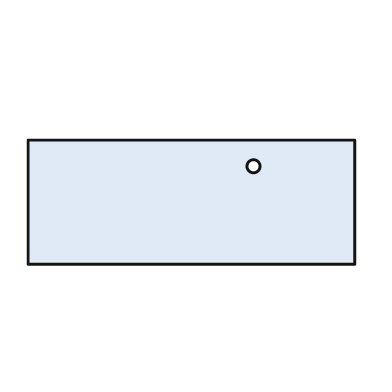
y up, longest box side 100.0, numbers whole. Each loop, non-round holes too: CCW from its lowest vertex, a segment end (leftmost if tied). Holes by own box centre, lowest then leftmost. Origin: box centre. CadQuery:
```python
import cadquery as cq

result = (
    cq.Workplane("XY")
    .moveTo(-50.0, -19.0)
    .lineTo(50.0, -19.0)
    .lineTo(50.0, 19.0)
    .lineTo(-50.0, 19.0)
    .close()
    .moveTo(19.0, 11.0)
    .circle(2.0)
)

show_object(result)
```